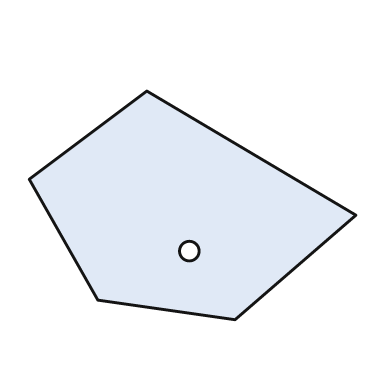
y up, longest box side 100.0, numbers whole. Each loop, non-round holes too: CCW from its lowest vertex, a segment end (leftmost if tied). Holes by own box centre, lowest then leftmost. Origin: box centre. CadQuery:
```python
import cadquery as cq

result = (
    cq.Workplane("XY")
    .moveTo(13.0, -35.0)
    .lineTo(50.0, -3.0)
    .lineTo(-14.0, 35.0)
    .lineTo(-50.0, 8.0)
    .lineTo(-29.0, -29.0)
    .close()
    .moveTo(-1.0, -14.0)
    .circle(3.0)
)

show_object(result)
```